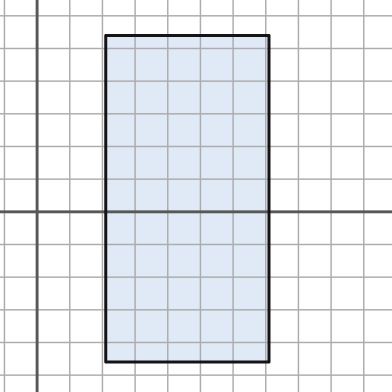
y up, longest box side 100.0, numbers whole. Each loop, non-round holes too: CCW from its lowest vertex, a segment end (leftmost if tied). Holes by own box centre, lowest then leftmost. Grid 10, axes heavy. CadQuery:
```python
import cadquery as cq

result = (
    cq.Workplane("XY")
    .moveTo(21.0, -46.0)
    .lineTo(71.0, -46.0)
    .lineTo(71.0, 54.0)
    .lineTo(21.0, 54.0)
    .close()
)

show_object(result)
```